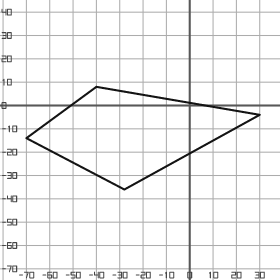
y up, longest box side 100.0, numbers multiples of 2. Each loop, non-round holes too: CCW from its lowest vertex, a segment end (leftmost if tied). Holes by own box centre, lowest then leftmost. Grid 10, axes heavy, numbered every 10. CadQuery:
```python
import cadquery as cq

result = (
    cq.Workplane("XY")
    .moveTo(-28.0, -36.0)
    .lineTo(30.0, -4.0)
    .lineTo(-40.0, 8.0)
    .lineTo(-70.0, -14.0)
    .close()
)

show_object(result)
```